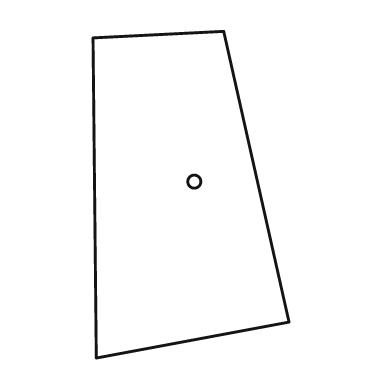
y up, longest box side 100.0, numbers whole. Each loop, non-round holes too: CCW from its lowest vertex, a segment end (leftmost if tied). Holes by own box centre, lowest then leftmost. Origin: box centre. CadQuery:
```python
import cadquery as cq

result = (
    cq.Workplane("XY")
    .moveTo(-29.0, -50.0)
    .lineTo(30.0, -39.0)
    .lineTo(10.0, 50.0)
    .lineTo(-30.0, 48.0)
    .close()
    .moveTo(1.0, 4.0)
    .circle(2.0)
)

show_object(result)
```